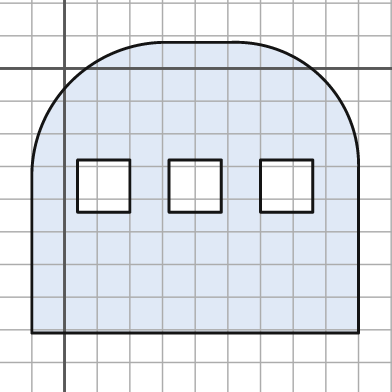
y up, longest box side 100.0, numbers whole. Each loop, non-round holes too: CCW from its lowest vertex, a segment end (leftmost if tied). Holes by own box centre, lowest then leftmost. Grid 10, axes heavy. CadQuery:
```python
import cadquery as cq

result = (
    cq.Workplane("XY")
    .moveTo(-10.0, -81.0)
    .lineTo(90.0, -81.0)
    .lineTo(90.0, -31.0)
    .threePointArc((79.0, -3.0), (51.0, 8.0))
    .lineTo(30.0, 8.0)
    .threePointArc((2.0, -4.0), (-10.0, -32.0))
    .close()
    .moveTo(4.0, -44.0)
    .lineTo(20.0, -44.0)
    .lineTo(20.0, -28.0)
    .lineTo(4.0, -28.0)
    .close()
    .moveTo(32.0, -44.0)
    .lineTo(48.0, -44.0)
    .lineTo(48.0, -28.0)
    .lineTo(32.0, -28.0)
    .close()
    .moveTo(60.0, -44.0)
    .lineTo(76.0, -44.0)
    .lineTo(76.0, -28.0)
    .lineTo(60.0, -28.0)
    .close()
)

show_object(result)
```